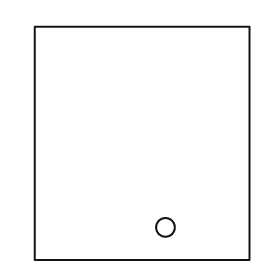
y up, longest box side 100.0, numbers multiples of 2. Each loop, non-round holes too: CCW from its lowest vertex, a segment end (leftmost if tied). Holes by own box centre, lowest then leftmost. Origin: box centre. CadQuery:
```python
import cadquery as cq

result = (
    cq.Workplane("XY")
    .moveTo(-46.0, -50.0)
    .lineTo(46.0, -50.0)
    .lineTo(46.0, 50.0)
    .lineTo(-46.0, 50.0)
    .close()
    .moveTo(10.0, -36.0)
    .circle(4.0)
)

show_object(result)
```